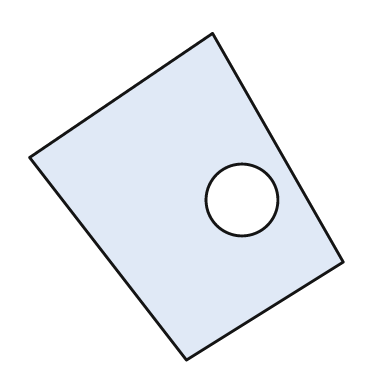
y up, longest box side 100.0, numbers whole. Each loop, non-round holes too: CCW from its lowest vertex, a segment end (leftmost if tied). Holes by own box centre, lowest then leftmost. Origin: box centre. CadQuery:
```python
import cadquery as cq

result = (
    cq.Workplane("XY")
    .moveTo(0.0, -50.0)
    .lineTo(48.0, -20.0)
    .lineTo(8.0, 50.0)
    .lineTo(-48.0, 12.0)
    .close()
    .moveTo(17.0, -1.0)
    .circle(11.0)
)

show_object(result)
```